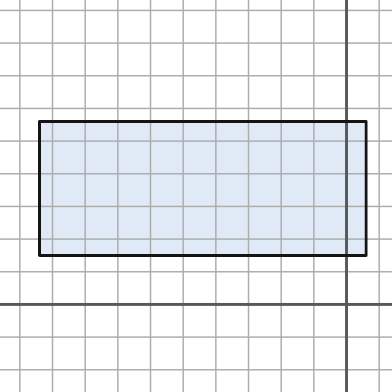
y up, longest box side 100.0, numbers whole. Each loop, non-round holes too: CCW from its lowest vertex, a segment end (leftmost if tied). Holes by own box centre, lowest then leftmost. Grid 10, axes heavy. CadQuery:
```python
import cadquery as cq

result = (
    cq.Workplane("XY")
    .moveTo(-94.0, 15.0)
    .lineTo(6.0, 15.0)
    .lineTo(6.0, 56.0)
    .lineTo(-94.0, 56.0)
    .close()
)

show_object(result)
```